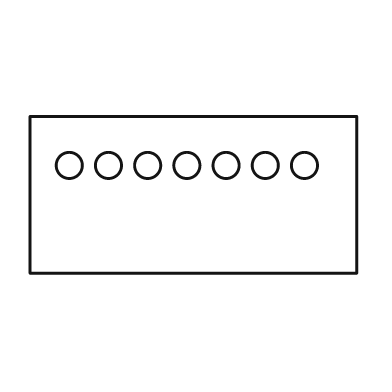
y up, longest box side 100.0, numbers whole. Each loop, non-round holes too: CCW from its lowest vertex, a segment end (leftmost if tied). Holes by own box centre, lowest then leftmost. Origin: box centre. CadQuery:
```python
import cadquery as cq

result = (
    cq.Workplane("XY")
    .moveTo(-50.0, -24.0)
    .lineTo(50.0, -24.0)
    .lineTo(50.0, 24.0)
    .lineTo(-50.0, 24.0)
    .close()
    .moveTo(-38.0, 9.0)
    .circle(4.0)
    .moveTo(-26.0, 9.0)
    .circle(4.0)
    .moveTo(-14.0, 9.0)
    .circle(4.0)
    .moveTo(-2.0, 9.0)
    .circle(4.0)
    .moveTo(10.0, 9.0)
    .circle(4.0)
    .moveTo(22.0, 9.0)
    .circle(4.0)
    .moveTo(34.0, 9.0)
    .circle(4.0)
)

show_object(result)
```